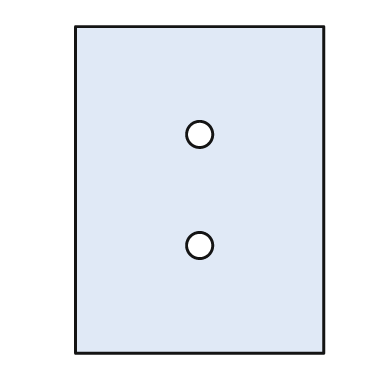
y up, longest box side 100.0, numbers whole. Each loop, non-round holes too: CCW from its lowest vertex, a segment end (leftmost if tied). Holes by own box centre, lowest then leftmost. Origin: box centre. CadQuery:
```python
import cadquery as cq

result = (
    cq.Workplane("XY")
    .moveTo(-38.0, -50.0)
    .lineTo(38.0, -50.0)
    .lineTo(38.0, 50.0)
    .lineTo(-38.0, 50.0)
    .close()
    .moveTo(0.0, -17.0)
    .circle(4.0)
    .moveTo(0.0, 17.0)
    .circle(4.0)
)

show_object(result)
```